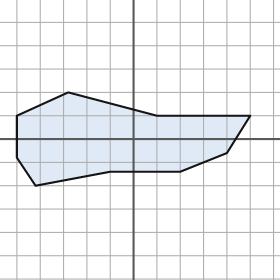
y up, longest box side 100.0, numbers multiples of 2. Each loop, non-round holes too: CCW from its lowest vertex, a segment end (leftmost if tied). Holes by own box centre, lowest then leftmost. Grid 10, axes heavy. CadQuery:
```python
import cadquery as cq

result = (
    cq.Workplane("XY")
    .moveTo(-42.0, -20.0)
    .lineTo(-10.0, -14.0)
    .lineTo(20.0, -14.0)
    .lineTo(40.0, -6.0)
    .lineTo(50.0, 10.0)
    .lineTo(10.0, 10.0)
    .lineTo(-28.0, 20.0)
    .lineTo(-50.0, 10.0)
    .lineTo(-50.0, -8.0)
    .close()
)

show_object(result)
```